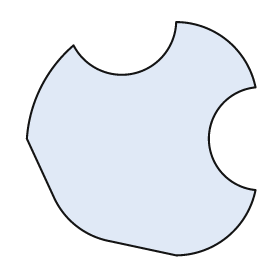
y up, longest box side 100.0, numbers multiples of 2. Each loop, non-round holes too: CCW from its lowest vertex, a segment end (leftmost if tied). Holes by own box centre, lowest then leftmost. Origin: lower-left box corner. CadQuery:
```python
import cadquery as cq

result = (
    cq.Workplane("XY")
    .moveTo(64.0, 0.0)
    .threePointArc((86.0, 8.0), (98.0, 28.0))
    .threePointArc((78.0, 50.0), (98.0, 72.0))
    .threePointArc((86.0, 92.0), (64.0, 100.0))
    .threePointArc((46.0, 78.0), (20.0, 90.0))
    .threePointArc((6.0, 72.0), (0.0, 50.0))
    .lineTo(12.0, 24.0)
    .threePointArc((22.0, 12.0), (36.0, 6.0))
    .close()
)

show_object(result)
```